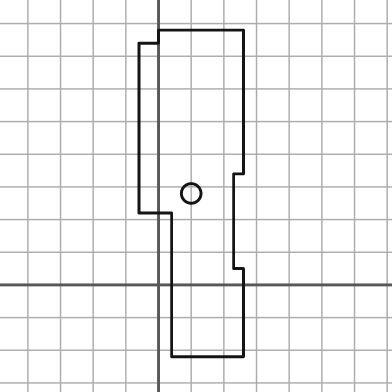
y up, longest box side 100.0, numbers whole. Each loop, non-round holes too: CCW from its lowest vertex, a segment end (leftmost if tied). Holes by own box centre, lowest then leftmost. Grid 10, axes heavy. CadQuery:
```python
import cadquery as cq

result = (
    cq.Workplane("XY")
    .moveTo(4.0, -22.0)
    .lineTo(26.0, -22.0)
    .lineTo(26.0, 5.0)
    .lineTo(23.0, 5.0)
    .lineTo(23.0, 34.0)
    .lineTo(26.0, 34.0)
    .lineTo(26.0, 78.0)
    .lineTo(0.0, 78.0)
    .lineTo(0.0, 74.0)
    .lineTo(-6.0, 74.0)
    .lineTo(-6.0, 22.0)
    .lineTo(4.0, 22.0)
    .close()
    .moveTo(10.0, 28.0)
    .circle(3.0)
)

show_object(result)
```